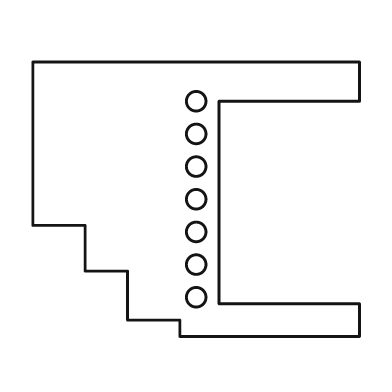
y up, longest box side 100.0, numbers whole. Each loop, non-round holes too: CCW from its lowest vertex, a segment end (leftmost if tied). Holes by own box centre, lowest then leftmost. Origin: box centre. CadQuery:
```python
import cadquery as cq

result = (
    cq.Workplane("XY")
    .moveTo(-5.0, -42.0)
    .lineTo(50.0, -42.0)
    .lineTo(50.0, -32.0)
    .lineTo(7.0, -32.0)
    .lineTo(7.0, 30.0)
    .lineTo(50.0, 30.0)
    .lineTo(50.0, 42.0)
    .lineTo(-50.0, 42.0)
    .lineTo(-50.0, -8.0)
    .lineTo(-34.0, -8.0)
    .lineTo(-34.0, -22.0)
    .lineTo(-21.0, -22.0)
    .lineTo(-21.0, -37.0)
    .lineTo(-5.0, -37.0)
    .close()
    .moveTo(0.0, -30.0)
    .circle(3.0)
    .moveTo(0.0, -20.0)
    .circle(3.0)
    .moveTo(0.0, -10.0)
    .circle(3.0)
    .moveTo(0.0, 0.0)
    .circle(3.0)
    .moveTo(0.0, 10.0)
    .circle(3.0)
    .moveTo(0.0, 20.0)
    .circle(3.0)
    .moveTo(0.0, 30.0)
    .circle(3.0)
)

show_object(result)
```